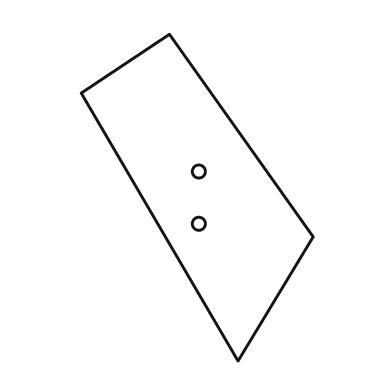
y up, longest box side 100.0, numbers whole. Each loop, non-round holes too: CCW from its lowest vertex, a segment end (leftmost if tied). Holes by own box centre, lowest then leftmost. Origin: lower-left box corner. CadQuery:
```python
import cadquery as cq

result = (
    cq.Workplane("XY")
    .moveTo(48.0, 0.0)
    .lineTo(71.0, 38.0)
    .lineTo(27.0, 100.0)
    .lineTo(0.0, 82.0)
    .close()
    .moveTo(36.0, 42.0)
    .circle(2.0)
    .moveTo(36.0, 58.0)
    .circle(2.0)
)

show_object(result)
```